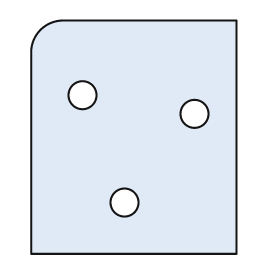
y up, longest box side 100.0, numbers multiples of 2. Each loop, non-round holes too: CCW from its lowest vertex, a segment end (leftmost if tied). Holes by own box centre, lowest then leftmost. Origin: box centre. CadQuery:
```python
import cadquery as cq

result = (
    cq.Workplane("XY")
    .moveTo(-44.0, -50.0)
    .lineTo(44.0, -50.0)
    .lineTo(44.0, 50.0)
    .lineTo(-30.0, 50.0)
    .threePointArc((-40.0, 46.0), (-44.0, 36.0))
    .close()
    .moveTo(-4.0, -28.0)
    .circle(6.0)
    .moveTo(26.0, 10.0)
    .circle(6.0)
    .moveTo(-22.0, 18.0)
    .circle(6.0)
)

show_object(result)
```